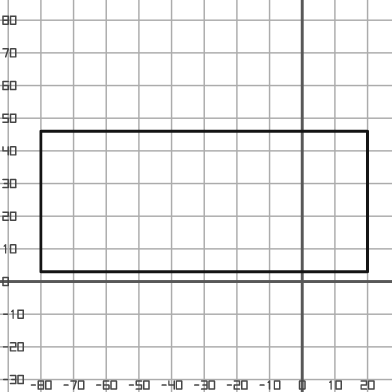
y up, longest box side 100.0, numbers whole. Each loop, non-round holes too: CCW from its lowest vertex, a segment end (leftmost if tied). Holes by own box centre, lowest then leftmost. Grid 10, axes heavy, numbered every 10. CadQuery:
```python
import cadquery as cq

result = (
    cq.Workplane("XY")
    .moveTo(-80.0, 3.0)
    .lineTo(20.0, 3.0)
    .lineTo(20.0, 46.0)
    .lineTo(-80.0, 46.0)
    .close()
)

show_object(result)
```